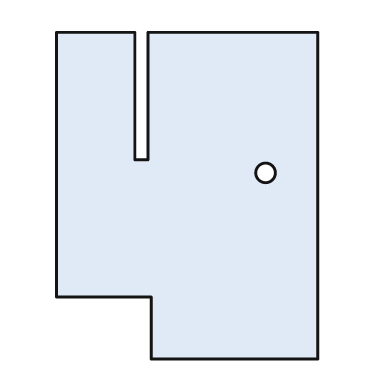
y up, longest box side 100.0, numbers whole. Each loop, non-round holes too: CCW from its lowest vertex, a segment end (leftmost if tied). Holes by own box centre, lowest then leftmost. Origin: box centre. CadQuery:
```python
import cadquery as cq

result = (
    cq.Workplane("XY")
    .moveTo(-11.0, -50.0)
    .lineTo(40.0, -50.0)
    .lineTo(40.0, 50.0)
    .lineTo(-12.0, 50.0)
    .lineTo(-12.0, 11.0)
    .lineTo(-16.0, 11.0)
    .lineTo(-16.0, 50.0)
    .lineTo(-40.0, 50.0)
    .lineTo(-40.0, -31.0)
    .lineTo(-11.0, -31.0)
    .close()
    .moveTo(24.0, 7.0)
    .circle(3.0)
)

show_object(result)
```